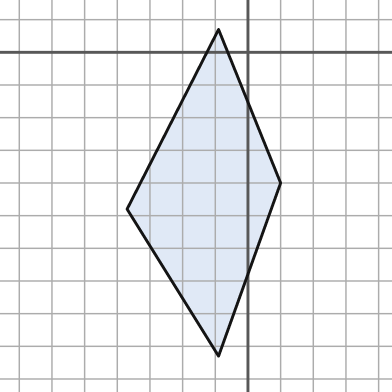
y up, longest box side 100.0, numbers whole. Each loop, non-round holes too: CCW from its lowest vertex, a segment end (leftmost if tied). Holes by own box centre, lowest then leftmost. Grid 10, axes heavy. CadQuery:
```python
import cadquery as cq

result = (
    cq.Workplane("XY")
    .moveTo(-9.0, -93.0)
    .lineTo(10.0, -40.0)
    .lineTo(-9.0, 7.0)
    .lineTo(-37.0, -48.0)
    .close()
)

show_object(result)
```